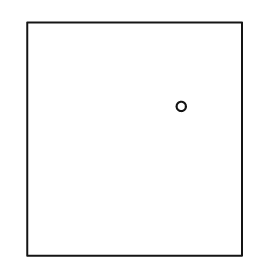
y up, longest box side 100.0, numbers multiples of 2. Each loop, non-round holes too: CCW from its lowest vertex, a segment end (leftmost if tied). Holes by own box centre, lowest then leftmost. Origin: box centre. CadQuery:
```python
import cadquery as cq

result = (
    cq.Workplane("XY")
    .moveTo(-46.0, -50.0)
    .lineTo(46.0, -50.0)
    .lineTo(46.0, 50.0)
    .lineTo(-46.0, 50.0)
    .close()
    .moveTo(20.0, 14.0)
    .circle(2.0)
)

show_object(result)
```